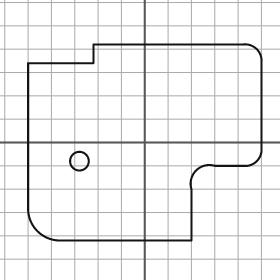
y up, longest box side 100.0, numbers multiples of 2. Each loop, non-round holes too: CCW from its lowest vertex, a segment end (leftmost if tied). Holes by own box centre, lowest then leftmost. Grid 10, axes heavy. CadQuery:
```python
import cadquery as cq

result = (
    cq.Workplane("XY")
    .moveTo(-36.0, -42.0)
    .lineTo(20.0, -42.0)
    .lineTo(20.0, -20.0)
    .threePointArc((22.0, -12.0), (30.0, -10.0))
    .lineTo(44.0, -10.0)
    .threePointArc((48.0, -8.0), (50.0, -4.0))
    .lineTo(50.0, 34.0)
    .threePointArc((48.0, 40.0), (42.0, 42.0))
    .lineTo(-22.0, 42.0)
    .lineTo(-22.0, 34.0)
    .lineTo(-50.0, 34.0)
    .lineTo(-50.0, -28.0)
    .threePointArc((-46.0, -38.0), (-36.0, -42.0))
    .close()
    .moveTo(-28.0, -8.0)
    .circle(4.0)
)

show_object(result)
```